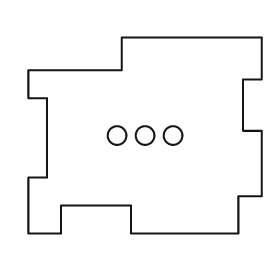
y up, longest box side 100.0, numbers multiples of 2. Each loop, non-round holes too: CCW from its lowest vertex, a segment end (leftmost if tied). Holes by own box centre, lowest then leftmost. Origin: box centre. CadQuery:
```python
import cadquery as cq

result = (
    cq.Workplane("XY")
    .moveTo(-50.0, -42.0)
    .lineTo(-36.0, -42.0)
    .lineTo(-36.0, -30.0)
    .lineTo(-6.0, -30.0)
    .lineTo(-6.0, -42.0)
    .lineTo(40.0, -42.0)
    .lineTo(40.0, -26.0)
    .lineTo(50.0, -26.0)
    .lineTo(50.0, 2.0)
    .lineTo(42.0, 2.0)
    .lineTo(42.0, 24.0)
    .lineTo(50.0, 24.0)
    .lineTo(50.0, 42.0)
    .lineTo(-10.0, 42.0)
    .lineTo(-10.0, 28.0)
    .lineTo(-50.0, 28.0)
    .lineTo(-50.0, 16.0)
    .lineTo(-42.0, 16.0)
    .lineTo(-42.0, -18.0)
    .lineTo(-50.0, -18.0)
    .close()
    .moveTo(-12.0, 0.0)
    .circle(4.0)
    .moveTo(0.0, 0.0)
    .circle(4.0)
    .moveTo(12.0, 0.0)
    .circle(4.0)
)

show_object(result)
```